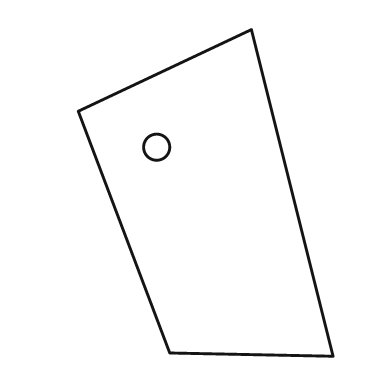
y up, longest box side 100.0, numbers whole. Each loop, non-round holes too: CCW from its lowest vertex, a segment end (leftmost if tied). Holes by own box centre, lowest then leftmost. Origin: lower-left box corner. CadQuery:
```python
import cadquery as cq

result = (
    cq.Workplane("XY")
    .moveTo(78.0, 0.0)
    .lineTo(53.0, 100.0)
    .lineTo(0.0, 75.0)
    .lineTo(28.0, 1.0)
    .close()
    .moveTo(24.0, 64.0)
    .circle(4.0)
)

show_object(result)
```